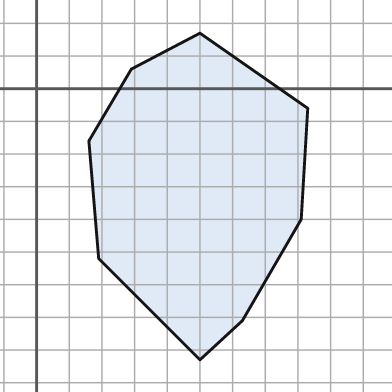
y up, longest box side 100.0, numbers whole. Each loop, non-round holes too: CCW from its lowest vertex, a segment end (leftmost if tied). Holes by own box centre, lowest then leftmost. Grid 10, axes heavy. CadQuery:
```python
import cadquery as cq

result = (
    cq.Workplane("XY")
    .moveTo(50.0, -83.0)
    .lineTo(63.0, -71.0)
    .lineTo(81.0, -40.0)
    .lineTo(83.0, -6.0)
    .lineTo(50.0, 17.0)
    .lineTo(29.0, 6.0)
    .lineTo(16.0, -16.0)
    .lineTo(19.0, -52.0)
    .close()
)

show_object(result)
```